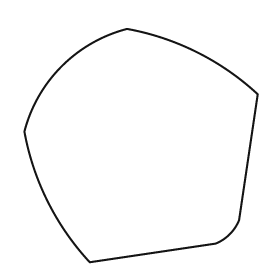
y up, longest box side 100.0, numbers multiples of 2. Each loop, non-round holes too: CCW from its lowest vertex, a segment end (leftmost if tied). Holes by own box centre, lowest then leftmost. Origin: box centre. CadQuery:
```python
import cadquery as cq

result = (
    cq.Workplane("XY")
    .moveTo(-22.0, -50.0)
    .lineTo(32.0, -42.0)
    .threePointArc((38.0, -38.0), (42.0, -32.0))
    .lineTo(50.0, 22.0)
    .threePointArc((24.0, 40.0), (-6.0, 50.0))
    .threePointArc((-34.0, 34.0), (-50.0, 6.0))
    .threePointArc((-40.0, -24.0), (-22.0, -50.0))
    .close()
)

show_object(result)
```